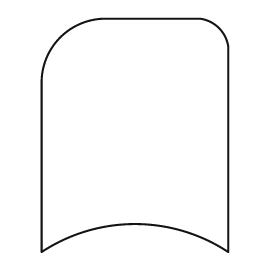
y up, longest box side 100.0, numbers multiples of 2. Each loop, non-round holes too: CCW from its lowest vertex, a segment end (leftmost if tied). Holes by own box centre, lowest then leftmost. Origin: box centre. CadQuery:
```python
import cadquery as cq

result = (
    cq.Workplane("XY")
    .moveTo(-40.0, -50.0)
    .threePointArc((0.0, -38.0), (40.0, -50.0))
    .lineTo(40.0, 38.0)
    .threePointArc((36.0, 46.0), (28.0, 50.0))
    .lineTo(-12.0, 50.0)
    .threePointArc((-32.0, 42.0), (-40.0, 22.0))
    .close()
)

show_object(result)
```